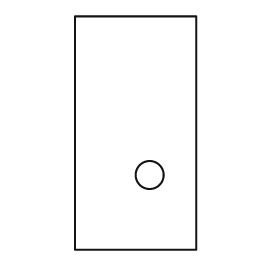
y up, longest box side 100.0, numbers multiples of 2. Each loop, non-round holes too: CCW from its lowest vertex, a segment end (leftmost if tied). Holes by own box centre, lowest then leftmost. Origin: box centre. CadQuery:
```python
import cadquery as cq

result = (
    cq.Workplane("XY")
    .moveTo(-26.0, -50.0)
    .lineTo(26.0, -50.0)
    .lineTo(26.0, 50.0)
    .lineTo(-26.0, 50.0)
    .close()
    .moveTo(6.0, -18.0)
    .circle(6.0)
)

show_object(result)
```